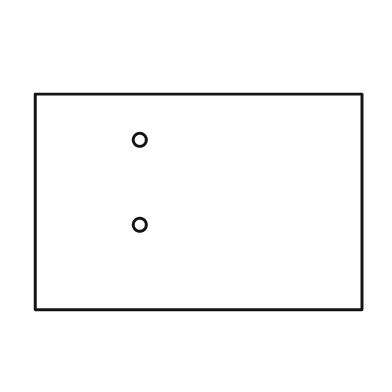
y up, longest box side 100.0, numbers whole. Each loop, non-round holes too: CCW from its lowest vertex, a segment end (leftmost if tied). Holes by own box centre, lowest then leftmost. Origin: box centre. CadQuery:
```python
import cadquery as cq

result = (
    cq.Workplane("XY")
    .moveTo(-50.0, -33.0)
    .lineTo(50.0, -33.0)
    .lineTo(50.0, 33.0)
    .lineTo(-50.0, 33.0)
    .close()
    .moveTo(-18.0, -7.0)
    .circle(2.0)
    .moveTo(-18.0, 19.0)
    .circle(2.0)
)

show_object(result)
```